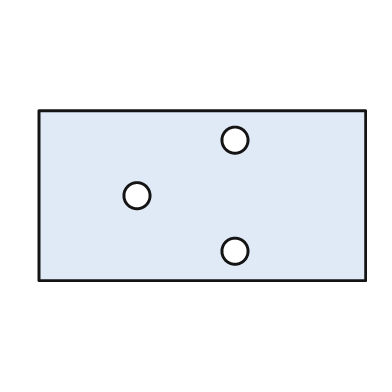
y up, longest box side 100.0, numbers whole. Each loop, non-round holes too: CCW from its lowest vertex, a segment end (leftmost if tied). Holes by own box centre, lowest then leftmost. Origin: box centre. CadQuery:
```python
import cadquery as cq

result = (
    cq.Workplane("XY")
    .moveTo(-50.0, -26.0)
    .lineTo(50.0, -26.0)
    .lineTo(50.0, 26.0)
    .lineTo(-50.0, 26.0)
    .close()
    .moveTo(10.0, -17.0)
    .circle(4.0)
    .moveTo(-20.0, 0.0)
    .circle(4.0)
    .moveTo(10.0, 17.0)
    .circle(4.0)
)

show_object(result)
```